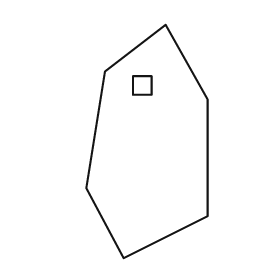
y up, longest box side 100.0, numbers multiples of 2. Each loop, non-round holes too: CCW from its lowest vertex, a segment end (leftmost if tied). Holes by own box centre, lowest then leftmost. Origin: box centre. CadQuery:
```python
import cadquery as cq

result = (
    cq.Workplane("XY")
    .moveTo(-10.0, -50.0)
    .lineTo(26.0, -32.0)
    .lineTo(26.0, 18.0)
    .lineTo(8.0, 50.0)
    .lineTo(-18.0, 30.0)
    .lineTo(-26.0, -20.0)
    .close()
    .moveTo(-6.0, 20.0)
    .lineTo(2.0, 20.0)
    .lineTo(2.0, 28.0)
    .lineTo(-6.0, 28.0)
    .close()
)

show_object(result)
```